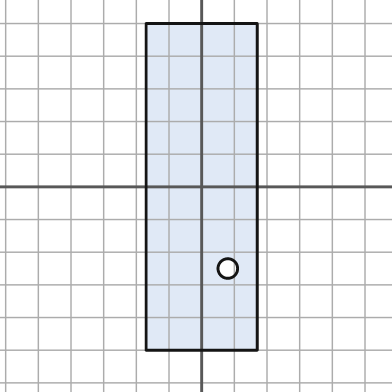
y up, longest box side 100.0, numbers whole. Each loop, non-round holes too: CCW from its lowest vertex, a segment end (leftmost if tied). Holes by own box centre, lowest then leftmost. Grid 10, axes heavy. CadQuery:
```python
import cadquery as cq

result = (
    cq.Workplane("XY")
    .moveTo(-17.0, -50.0)
    .lineTo(17.0, -50.0)
    .lineTo(17.0, 50.0)
    .lineTo(-17.0, 50.0)
    .close()
    .moveTo(8.0, -25.0)
    .circle(3.0)
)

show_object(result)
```